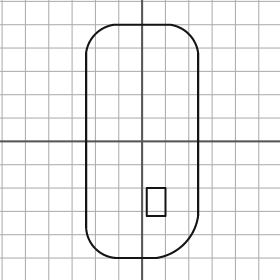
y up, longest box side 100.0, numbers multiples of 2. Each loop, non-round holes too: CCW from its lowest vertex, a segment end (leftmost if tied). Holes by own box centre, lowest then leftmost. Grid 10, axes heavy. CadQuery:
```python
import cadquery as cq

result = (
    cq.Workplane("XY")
    .moveTo(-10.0, -50.0)
    .lineTo(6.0, -50.0)
    .threePointArc((18.0, -44.0), (24.0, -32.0))
    .lineTo(24.0, 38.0)
    .threePointArc((20.0, 46.0), (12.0, 50.0))
    .lineTo(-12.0, 50.0)
    .threePointArc((-20.0, 46.0), (-24.0, 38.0))
    .lineTo(-24.0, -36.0)
    .threePointArc((-20.0, -46.0), (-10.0, -50.0))
    .close()
    .moveTo(2.0, -32.0)
    .lineTo(10.0, -32.0)
    .lineTo(10.0, -20.0)
    .lineTo(2.0, -20.0)
    .close()
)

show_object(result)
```